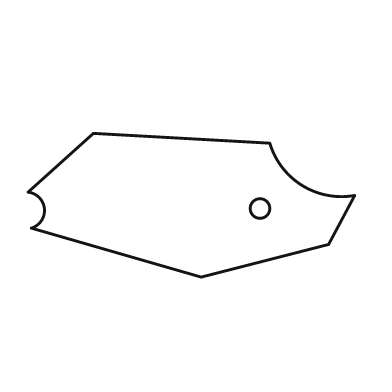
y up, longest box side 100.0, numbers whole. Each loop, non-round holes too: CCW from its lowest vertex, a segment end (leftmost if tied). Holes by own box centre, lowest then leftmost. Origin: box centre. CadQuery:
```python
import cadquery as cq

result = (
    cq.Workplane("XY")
    .moveTo(3.0, -22.0)
    .lineTo(42.0, -12.0)
    .lineTo(50.0, 3.0)
    .threePointArc((34.0, 6.0), (24.0, 19.0))
    .lineTo(-30.0, 22.0)
    .lineTo(-50.0, 4.0)
    .threePointArc((-45.0, -1.0), (-49.0, -7.0))
    .close()
    .moveTo(21.0, -1.0)
    .circle(3.0)
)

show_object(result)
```